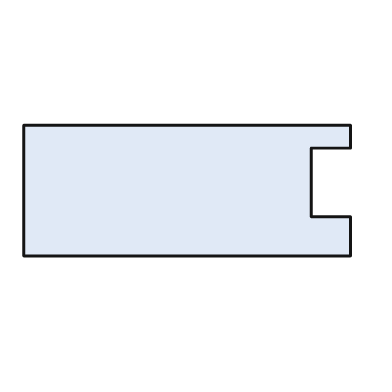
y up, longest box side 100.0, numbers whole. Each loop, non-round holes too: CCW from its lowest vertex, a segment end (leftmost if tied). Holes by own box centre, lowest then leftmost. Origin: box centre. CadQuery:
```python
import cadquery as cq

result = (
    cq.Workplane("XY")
    .moveTo(-50.0, -20.0)
    .lineTo(50.0, -20.0)
    .lineTo(50.0, -8.0)
    .lineTo(38.0, -8.0)
    .lineTo(38.0, 13.0)
    .lineTo(50.0, 13.0)
    .lineTo(50.0, 20.0)
    .lineTo(-50.0, 20.0)
    .close()
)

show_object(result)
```